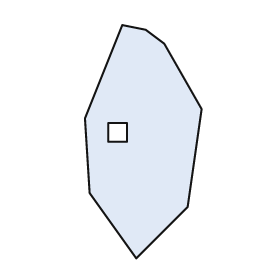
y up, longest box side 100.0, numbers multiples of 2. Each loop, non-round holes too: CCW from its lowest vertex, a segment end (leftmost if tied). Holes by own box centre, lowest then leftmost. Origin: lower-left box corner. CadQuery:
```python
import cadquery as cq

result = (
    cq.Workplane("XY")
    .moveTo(22.0, 0.0)
    .lineTo(44.0, 22.0)
    .lineTo(50.0, 64.0)
    .lineTo(34.0, 92.0)
    .lineTo(26.0, 98.0)
    .lineTo(16.0, 100.0)
    .lineTo(0.0, 60.0)
    .lineTo(2.0, 28.0)
    .close()
    .moveTo(10.0, 50.0)
    .lineTo(18.0, 50.0)
    .lineTo(18.0, 58.0)
    .lineTo(10.0, 58.0)
    .close()
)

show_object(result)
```